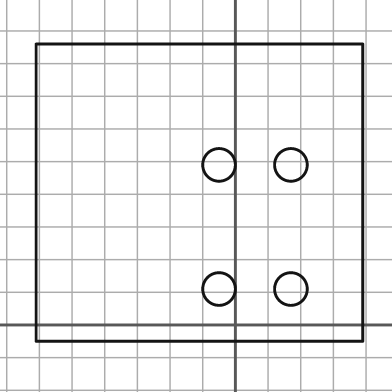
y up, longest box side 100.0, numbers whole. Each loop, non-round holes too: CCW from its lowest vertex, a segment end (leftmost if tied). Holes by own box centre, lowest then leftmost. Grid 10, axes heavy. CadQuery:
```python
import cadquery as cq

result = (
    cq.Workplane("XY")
    .moveTo(-61.0, -5.0)
    .lineTo(39.0, -5.0)
    .lineTo(39.0, 86.0)
    .lineTo(-61.0, 86.0)
    .close()
    .moveTo(-5.0, 11.0)
    .circle(5.0)
    .moveTo(17.0, 11.0)
    .circle(5.0)
    .moveTo(-5.0, 49.0)
    .circle(5.0)
    .moveTo(17.0, 49.0)
    .circle(5.0)
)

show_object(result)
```